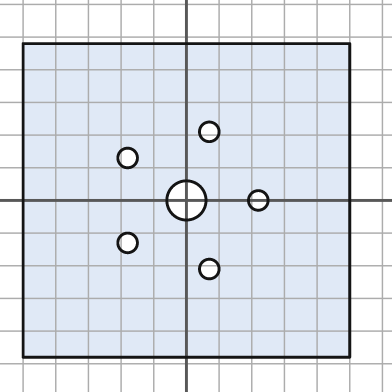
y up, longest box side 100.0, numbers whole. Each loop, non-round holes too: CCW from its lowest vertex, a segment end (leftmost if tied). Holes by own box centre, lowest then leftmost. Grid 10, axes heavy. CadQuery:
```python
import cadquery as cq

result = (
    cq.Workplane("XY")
    .moveTo(-50.0, -48.0)
    .lineTo(50.0, -48.0)
    .lineTo(50.0, 48.0)
    .lineTo(-50.0, 48.0)
    .close()
    .moveTo(7.0, -21.0)
    .circle(3.0)
    .moveTo(-18.0, -13.0)
    .circle(3.0)
    .moveTo(0.0, 0.0)
    .circle(6.0)
    .moveTo(22.0, 0.0)
    .circle(3.0)
    .moveTo(-18.0, 13.0)
    .circle(3.0)
    .moveTo(7.0, 21.0)
    .circle(3.0)
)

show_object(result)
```